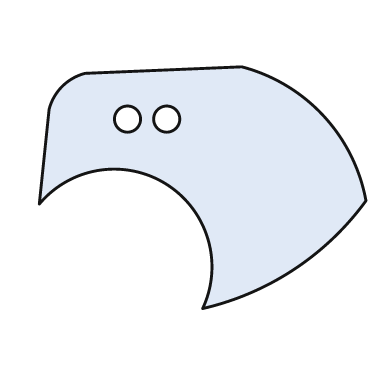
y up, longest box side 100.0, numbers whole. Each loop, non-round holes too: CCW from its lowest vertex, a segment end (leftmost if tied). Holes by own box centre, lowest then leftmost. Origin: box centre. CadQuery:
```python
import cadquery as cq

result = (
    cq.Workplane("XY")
    .moveTo(0.0, -37.0)
    .threePointArc((28.0, -25.0), (50.0, -4.0))
    .threePointArc((37.0, 22.0), (12.0, 37.0))
    .lineTo(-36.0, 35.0)
    .threePointArc((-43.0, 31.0), (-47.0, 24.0))
    .lineTo(-50.0, -5.0)
    .threePointArc((-11.0, 1.0), (0.0, -37.0))
    .close()
    .moveTo(-23.0, 21.0)
    .circle(4.0)
    .moveTo(-11.0, 21.0)
    .circle(4.0)
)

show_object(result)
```